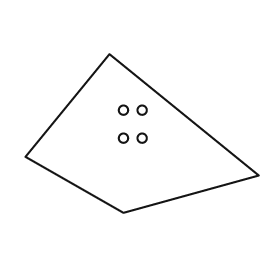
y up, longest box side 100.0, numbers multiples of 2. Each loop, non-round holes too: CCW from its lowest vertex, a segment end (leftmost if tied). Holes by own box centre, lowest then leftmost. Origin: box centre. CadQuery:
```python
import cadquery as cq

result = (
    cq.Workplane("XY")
    .moveTo(-8.0, -34.0)
    .lineTo(50.0, -18.0)
    .lineTo(-14.0, 34.0)
    .lineTo(-50.0, -10.0)
    .close()
    .moveTo(-8.0, -2.0)
    .circle(2.0)
    .moveTo(0.0, -2.0)
    .circle(2.0)
    .moveTo(-8.0, 10.0)
    .circle(2.0)
    .moveTo(0.0, 10.0)
    .circle(2.0)
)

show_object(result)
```